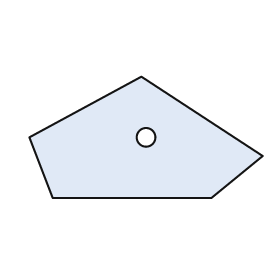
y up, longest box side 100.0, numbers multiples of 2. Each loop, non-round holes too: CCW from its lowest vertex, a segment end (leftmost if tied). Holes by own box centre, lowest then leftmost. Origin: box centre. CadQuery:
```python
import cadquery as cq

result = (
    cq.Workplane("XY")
    .moveTo(-40.0, -26.0)
    .lineTo(28.0, -26.0)
    .lineTo(50.0, -8.0)
    .lineTo(-2.0, 26.0)
    .lineTo(-50.0, 0.0)
    .close()
    .moveTo(0.0, 0.0)
    .circle(4.0)
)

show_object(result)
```